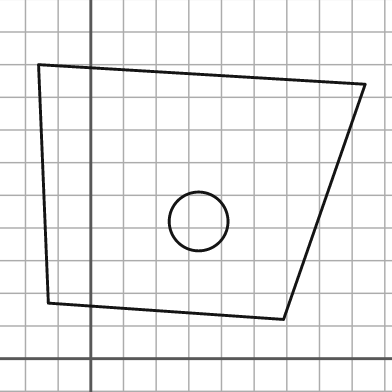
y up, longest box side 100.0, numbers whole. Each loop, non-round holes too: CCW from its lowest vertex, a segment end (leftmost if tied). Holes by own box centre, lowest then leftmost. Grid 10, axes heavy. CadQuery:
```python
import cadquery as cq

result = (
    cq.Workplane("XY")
    .moveTo(59.0, 12.0)
    .lineTo(84.0, 84.0)
    .lineTo(-16.0, 90.0)
    .lineTo(-13.0, 17.0)
    .close()
    .moveTo(33.0, 42.0)
    .circle(9.0)
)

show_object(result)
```